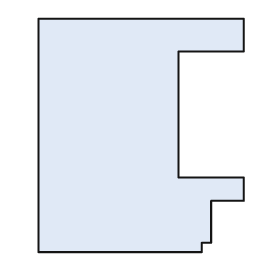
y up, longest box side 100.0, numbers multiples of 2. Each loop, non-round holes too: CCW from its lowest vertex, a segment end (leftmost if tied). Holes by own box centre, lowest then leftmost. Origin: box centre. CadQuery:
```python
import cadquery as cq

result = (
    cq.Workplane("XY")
    .moveTo(-44.0, -50.0)
    .lineTo(26.0, -50.0)
    .lineTo(26.0, -46.0)
    .lineTo(30.0, -46.0)
    .lineTo(30.0, -28.0)
    .lineTo(44.0, -28.0)
    .lineTo(44.0, -18.0)
    .lineTo(16.0, -18.0)
    .lineTo(16.0, 36.0)
    .lineTo(44.0, 36.0)
    .lineTo(44.0, 50.0)
    .lineTo(-44.0, 50.0)
    .close()
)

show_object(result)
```